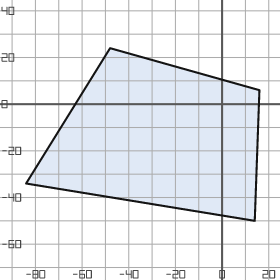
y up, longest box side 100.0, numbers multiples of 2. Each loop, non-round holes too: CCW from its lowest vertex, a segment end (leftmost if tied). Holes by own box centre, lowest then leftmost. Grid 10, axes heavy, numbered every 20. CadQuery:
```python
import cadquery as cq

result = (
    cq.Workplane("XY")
    .moveTo(14.0, -50.0)
    .lineTo(16.0, 6.0)
    .lineTo(-48.0, 24.0)
    .lineTo(-84.0, -34.0)
    .close()
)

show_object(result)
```